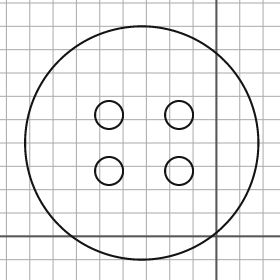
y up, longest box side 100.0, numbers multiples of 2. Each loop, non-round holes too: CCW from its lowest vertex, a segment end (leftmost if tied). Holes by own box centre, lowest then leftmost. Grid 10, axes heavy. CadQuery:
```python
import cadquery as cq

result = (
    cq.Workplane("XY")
    .moveTo(-32.0, 40.0)
    .circle(50.0)
    .moveTo(-46.0, 28.0)
    .circle(6.0)
    .moveTo(-16.0, 28.0)
    .circle(6.0)
    .moveTo(-46.0, 52.0)
    .circle(6.0)
    .moveTo(-16.0, 52.0)
    .circle(6.0)
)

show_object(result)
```